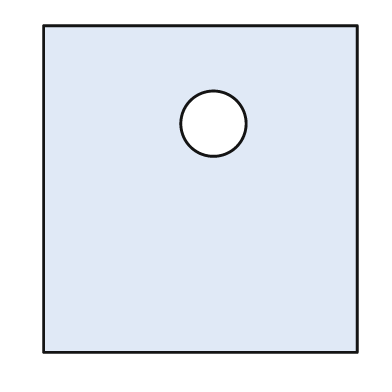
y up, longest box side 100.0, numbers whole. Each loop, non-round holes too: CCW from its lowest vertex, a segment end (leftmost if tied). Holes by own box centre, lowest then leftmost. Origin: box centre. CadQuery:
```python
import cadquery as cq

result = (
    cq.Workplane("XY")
    .moveTo(-48.0, -50.0)
    .lineTo(48.0, -50.0)
    .lineTo(48.0, 50.0)
    .lineTo(-48.0, 50.0)
    .close()
    .moveTo(4.0, 20.0)
    .circle(10.0)
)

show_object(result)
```